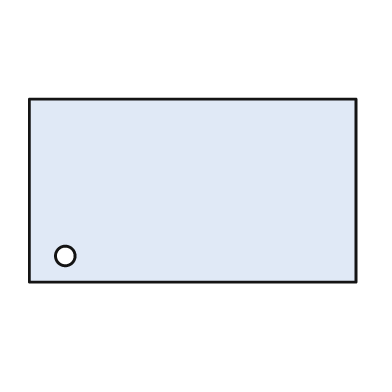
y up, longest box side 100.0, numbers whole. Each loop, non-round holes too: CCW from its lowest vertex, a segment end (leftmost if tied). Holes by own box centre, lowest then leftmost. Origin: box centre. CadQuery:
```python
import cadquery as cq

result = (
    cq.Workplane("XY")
    .moveTo(-50.0, -28.0)
    .lineTo(50.0, -28.0)
    .lineTo(50.0, 28.0)
    .lineTo(-50.0, 28.0)
    .close()
    .moveTo(-39.0, -20.0)
    .circle(3.0)
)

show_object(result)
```